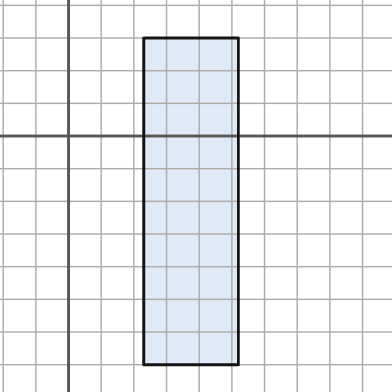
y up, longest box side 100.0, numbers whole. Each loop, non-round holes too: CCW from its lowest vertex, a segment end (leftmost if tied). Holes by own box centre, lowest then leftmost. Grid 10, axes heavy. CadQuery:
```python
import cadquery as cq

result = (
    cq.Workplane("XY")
    .moveTo(23.0, -70.0)
    .lineTo(52.0, -70.0)
    .lineTo(52.0, 30.0)
    .lineTo(23.0, 30.0)
    .close()
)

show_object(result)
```